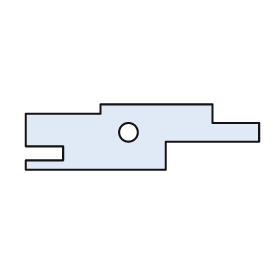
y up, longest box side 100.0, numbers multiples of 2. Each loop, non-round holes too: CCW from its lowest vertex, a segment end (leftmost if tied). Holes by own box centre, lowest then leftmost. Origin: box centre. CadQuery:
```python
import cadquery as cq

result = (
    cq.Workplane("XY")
    .moveTo(-50.0, -14.0)
    .lineTo(10.0, -14.0)
    .lineTo(10.0, -2.0)
    .lineTo(50.0, -2.0)
    .lineTo(50.0, 6.0)
    .lineTo(30.0, 6.0)
    .lineTo(30.0, 14.0)
    .lineTo(-18.0, 14.0)
    .lineTo(-18.0, 10.0)
    .lineTo(-50.0, 10.0)
    .lineTo(-50.0, -4.0)
    .lineTo(-34.0, -4.0)
    .lineTo(-34.0, -10.0)
    .lineTo(-50.0, -10.0)
    .close()
    .moveTo(-6.0, 2.0)
    .circle(4.0)
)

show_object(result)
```